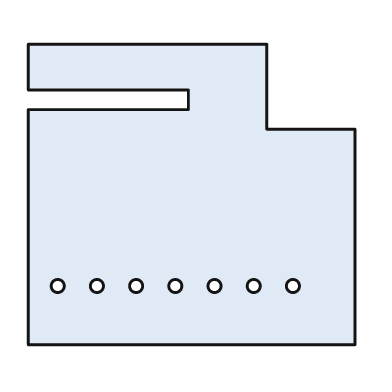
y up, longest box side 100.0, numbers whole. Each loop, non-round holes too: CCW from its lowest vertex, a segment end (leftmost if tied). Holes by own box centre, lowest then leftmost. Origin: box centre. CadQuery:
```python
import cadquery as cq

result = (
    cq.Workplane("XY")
    .moveTo(-50.0, -46.0)
    .lineTo(50.0, -46.0)
    .lineTo(50.0, 20.0)
    .lineTo(23.0, 20.0)
    .lineTo(23.0, 46.0)
    .lineTo(-50.0, 46.0)
    .lineTo(-50.0, 32.0)
    .lineTo(-1.0, 32.0)
    .lineTo(-1.0, 26.0)
    .lineTo(-50.0, 26.0)
    .close()
    .moveTo(-41.0, -28.0)
    .circle(2.0)
    .moveTo(-29.0, -28.0)
    .circle(2.0)
    .moveTo(-17.0, -28.0)
    .circle(2.0)
    .moveTo(-5.0, -28.0)
    .circle(2.0)
    .moveTo(7.0, -28.0)
    .circle(2.0)
    .moveTo(19.0, -28.0)
    .circle(2.0)
    .moveTo(31.0, -28.0)
    .circle(2.0)
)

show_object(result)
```